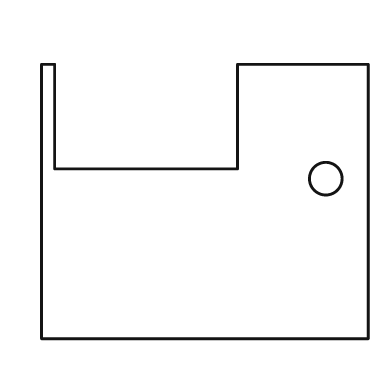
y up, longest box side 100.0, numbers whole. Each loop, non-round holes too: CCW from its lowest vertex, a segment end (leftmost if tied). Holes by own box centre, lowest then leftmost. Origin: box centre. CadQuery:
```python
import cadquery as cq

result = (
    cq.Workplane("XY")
    .moveTo(-50.0, -42.0)
    .lineTo(50.0, -42.0)
    .lineTo(50.0, 42.0)
    .lineTo(10.0, 42.0)
    .lineTo(10.0, 10.0)
    .lineTo(-46.0, 10.0)
    .lineTo(-46.0, 42.0)
    .lineTo(-50.0, 42.0)
    .close()
    .moveTo(37.0, 7.0)
    .circle(5.0)
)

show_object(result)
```